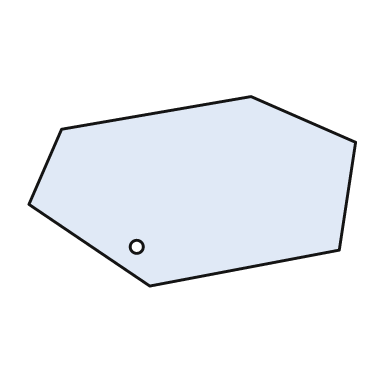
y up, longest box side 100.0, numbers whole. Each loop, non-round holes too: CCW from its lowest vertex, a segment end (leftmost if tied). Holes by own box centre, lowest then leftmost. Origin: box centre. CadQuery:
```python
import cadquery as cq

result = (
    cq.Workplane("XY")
    .moveTo(-13.0, -29.0)
    .lineTo(45.0, -18.0)
    .lineTo(50.0, 15.0)
    .lineTo(18.0, 29.0)
    .lineTo(-40.0, 19.0)
    .lineTo(-50.0, -4.0)
    .close()
    .moveTo(-17.0, -17.0)
    .circle(2.0)
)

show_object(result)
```